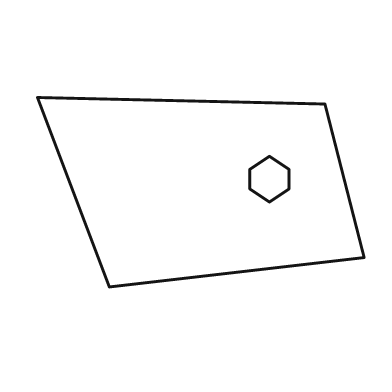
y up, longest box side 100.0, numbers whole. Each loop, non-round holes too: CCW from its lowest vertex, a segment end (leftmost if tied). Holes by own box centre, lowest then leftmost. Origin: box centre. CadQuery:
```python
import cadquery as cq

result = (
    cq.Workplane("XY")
    .moveTo(-28.0, -29.0)
    .lineTo(50.0, -20.0)
    .lineTo(38.0, 27.0)
    .lineTo(-50.0, 29.0)
    .close()
    .moveTo(21.0, -3.0)
    .lineTo(27.0, 1.0)
    .lineTo(27.0, 7.0)
    .lineTo(21.0, 11.0)
    .lineTo(15.0, 7.0)
    .lineTo(15.0, 1.0)
    .close()
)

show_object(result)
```